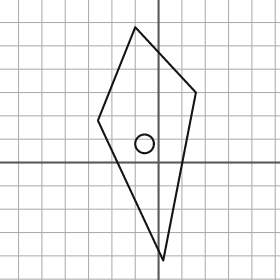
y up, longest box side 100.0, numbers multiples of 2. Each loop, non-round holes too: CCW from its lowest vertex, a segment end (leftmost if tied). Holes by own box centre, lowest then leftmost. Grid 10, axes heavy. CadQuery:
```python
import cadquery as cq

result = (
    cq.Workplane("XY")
    .moveTo(2.0, -42.0)
    .lineTo(16.0, 30.0)
    .lineTo(-10.0, 58.0)
    .lineTo(-26.0, 18.0)
    .close()
    .moveTo(-6.0, 8.0)
    .circle(4.0)
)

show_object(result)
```